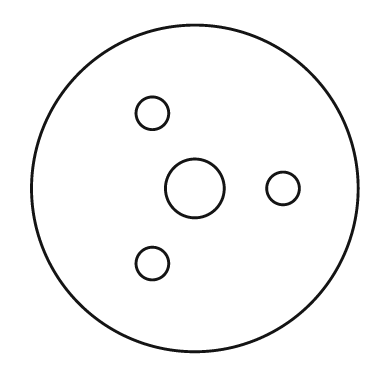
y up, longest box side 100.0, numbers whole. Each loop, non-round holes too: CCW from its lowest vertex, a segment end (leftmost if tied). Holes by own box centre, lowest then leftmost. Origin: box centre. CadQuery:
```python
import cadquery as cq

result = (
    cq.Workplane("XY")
    .moveTo(0.0, 0.0)
    .circle(50.0)
    .moveTo(-13.0, -23.0)
    .circle(5.0)
    .moveTo(0.0, 0.0)
    .circle(9.0)
    .moveTo(27.0, 0.0)
    .circle(5.0)
    .moveTo(-13.0, 23.0)
    .circle(5.0)
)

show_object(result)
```